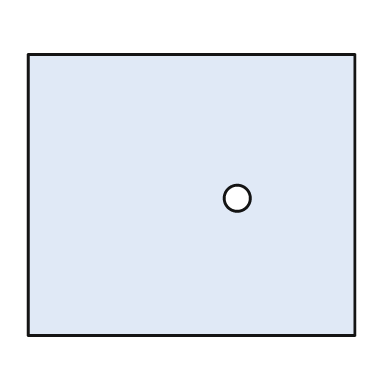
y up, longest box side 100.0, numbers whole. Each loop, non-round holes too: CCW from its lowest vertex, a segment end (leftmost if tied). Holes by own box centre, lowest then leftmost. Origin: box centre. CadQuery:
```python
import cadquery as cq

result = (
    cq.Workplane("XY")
    .moveTo(-50.0, -43.0)
    .lineTo(50.0, -43.0)
    .lineTo(50.0, 43.0)
    .lineTo(-50.0, 43.0)
    .close()
    .moveTo(14.0, -1.0)
    .circle(4.0)
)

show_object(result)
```